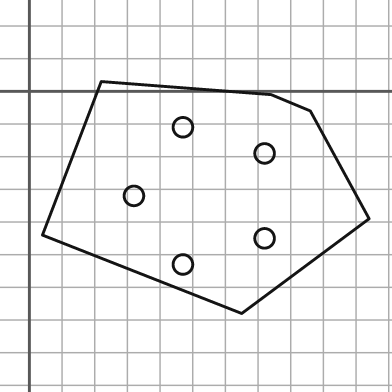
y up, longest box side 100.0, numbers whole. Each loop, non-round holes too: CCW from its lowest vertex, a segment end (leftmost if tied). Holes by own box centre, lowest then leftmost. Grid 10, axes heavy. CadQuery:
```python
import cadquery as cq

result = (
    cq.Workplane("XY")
    .moveTo(65.0, -68.0)
    .lineTo(104.0, -39.0)
    .lineTo(86.0, -6.0)
    .lineTo(74.0, -1.0)
    .lineTo(22.0, 3.0)
    .lineTo(4.0, -44.0)
    .close()
    .moveTo(47.0, -53.0)
    .circle(3.0)
    .moveTo(72.0, -45.0)
    .circle(3.0)
    .moveTo(32.0, -32.0)
    .circle(3.0)
    .moveTo(72.0, -19.0)
    .circle(3.0)
    .moveTo(47.0, -11.0)
    .circle(3.0)
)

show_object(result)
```